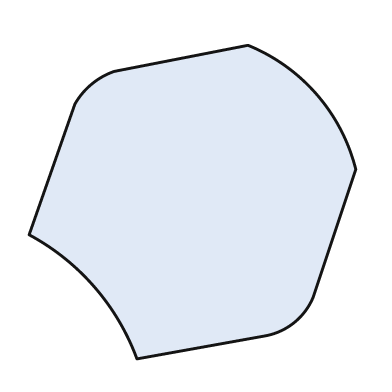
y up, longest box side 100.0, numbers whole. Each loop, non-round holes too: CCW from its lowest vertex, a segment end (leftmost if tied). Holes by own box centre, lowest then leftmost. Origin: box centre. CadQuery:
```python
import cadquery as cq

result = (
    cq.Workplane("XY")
    .moveTo(-17.0, -48.0)
    .lineTo(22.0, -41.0)
    .threePointArc((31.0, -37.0), (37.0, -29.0))
    .lineTo(50.0, 10.0)
    .threePointArc((38.0, 33.0), (17.0, 48.0))
    .lineTo(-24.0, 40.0)
    .threePointArc((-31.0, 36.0), (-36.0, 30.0))
    .lineTo(-50.0, -10.0)
    .threePointArc((-30.0, -26.0), (-17.0, -48.0))
    .close()
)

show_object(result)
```